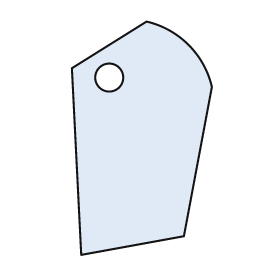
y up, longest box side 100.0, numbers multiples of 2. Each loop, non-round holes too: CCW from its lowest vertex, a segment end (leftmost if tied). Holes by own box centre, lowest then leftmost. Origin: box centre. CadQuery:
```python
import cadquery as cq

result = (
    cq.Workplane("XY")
    .moveTo(-26.0, -50.0)
    .lineTo(18.0, -42.0)
    .lineTo(30.0, 22.0)
    .threePointArc((20.0, 40.0), (2.0, 50.0))
    .lineTo(-30.0, 30.0)
    .close()
    .moveTo(-14.0, 26.0)
    .circle(6.0)
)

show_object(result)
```